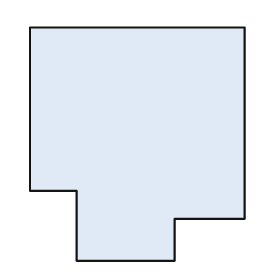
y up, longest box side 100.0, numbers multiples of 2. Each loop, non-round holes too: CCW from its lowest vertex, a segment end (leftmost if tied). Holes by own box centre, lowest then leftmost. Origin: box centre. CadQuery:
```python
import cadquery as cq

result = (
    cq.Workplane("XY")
    .moveTo(-26.0, -50.0)
    .lineTo(16.0, -50.0)
    .lineTo(16.0, -32.0)
    .lineTo(46.0, -32.0)
    .lineTo(46.0, 50.0)
    .lineTo(-46.0, 50.0)
    .lineTo(-46.0, -20.0)
    .lineTo(-26.0, -20.0)
    .close()
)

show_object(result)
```